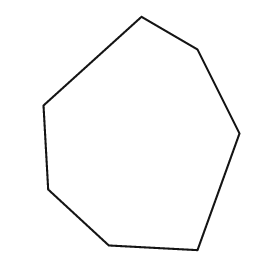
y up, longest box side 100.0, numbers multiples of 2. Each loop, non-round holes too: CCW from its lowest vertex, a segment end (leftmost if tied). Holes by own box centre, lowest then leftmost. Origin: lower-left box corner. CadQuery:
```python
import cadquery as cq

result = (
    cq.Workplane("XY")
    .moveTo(66.0, 0.0)
    .lineTo(84.0, 50.0)
    .lineTo(66.0, 86.0)
    .lineTo(42.0, 100.0)
    .lineTo(0.0, 62.0)
    .lineTo(2.0, 26.0)
    .lineTo(28.0, 2.0)
    .close()
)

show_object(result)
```